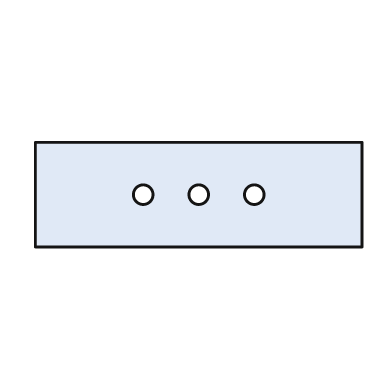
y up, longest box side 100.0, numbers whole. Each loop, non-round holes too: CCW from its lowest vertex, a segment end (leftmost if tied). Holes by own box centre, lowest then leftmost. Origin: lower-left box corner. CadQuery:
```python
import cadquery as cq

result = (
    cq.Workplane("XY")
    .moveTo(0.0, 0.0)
    .lineTo(100.0, 0.0)
    .lineTo(100.0, 32.0)
    .lineTo(0.0, 32.0)
    .close()
    .moveTo(33.0, 16.0)
    .circle(3.0)
    .moveTo(50.0, 16.0)
    .circle(3.0)
    .moveTo(67.0, 16.0)
    .circle(3.0)
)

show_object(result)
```